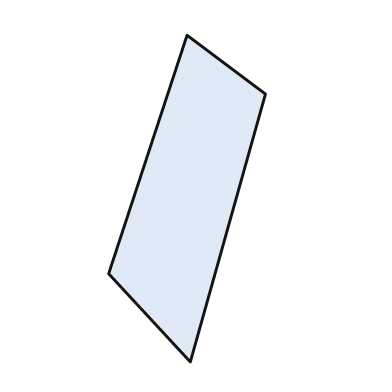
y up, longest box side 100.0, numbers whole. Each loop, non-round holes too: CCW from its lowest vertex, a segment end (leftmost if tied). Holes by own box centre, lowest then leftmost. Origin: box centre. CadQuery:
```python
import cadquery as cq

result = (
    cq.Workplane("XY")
    .moveTo(1.0, -50.0)
    .lineTo(24.0, 32.0)
    .lineTo(0.0, 50.0)
    .lineTo(-24.0, -23.0)
    .close()
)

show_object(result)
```